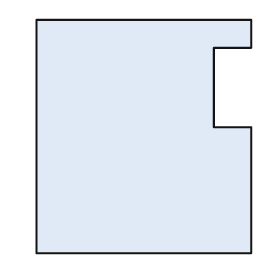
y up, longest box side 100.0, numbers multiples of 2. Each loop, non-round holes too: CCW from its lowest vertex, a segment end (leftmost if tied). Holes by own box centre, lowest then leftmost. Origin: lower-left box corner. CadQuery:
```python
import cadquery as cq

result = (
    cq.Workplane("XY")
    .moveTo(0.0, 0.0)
    .lineTo(92.0, 0.0)
    .lineTo(92.0, 54.0)
    .lineTo(76.0, 54.0)
    .lineTo(76.0, 88.0)
    .lineTo(92.0, 88.0)
    .lineTo(92.0, 100.0)
    .lineTo(0.0, 100.0)
    .close()
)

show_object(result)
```